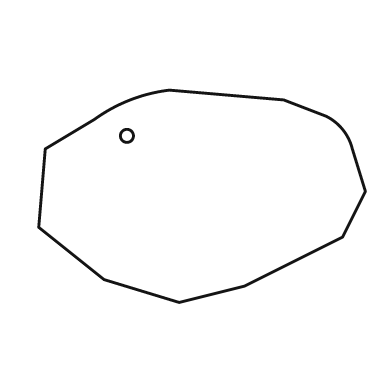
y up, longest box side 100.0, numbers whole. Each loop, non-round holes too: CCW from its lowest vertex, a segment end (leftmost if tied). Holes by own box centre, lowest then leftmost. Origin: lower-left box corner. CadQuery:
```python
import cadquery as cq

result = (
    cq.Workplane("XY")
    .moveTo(43.0, 0.0)
    .lineTo(63.0, 5.0)
    .lineTo(93.0, 20.0)
    .lineTo(100.0, 34.0)
    .lineTo(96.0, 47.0)
    .threePointArc((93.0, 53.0), (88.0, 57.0))
    .lineTo(75.0, 62.0)
    .lineTo(40.0, 65.0)
    .threePointArc((28.0, 62.0), (17.0, 56.0))
    .lineTo(2.0, 47.0)
    .lineTo(0.0, 23.0)
    .lineTo(20.0, 7.0)
    .close()
    .moveTo(27.0, 51.0)
    .circle(2.0)
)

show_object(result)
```